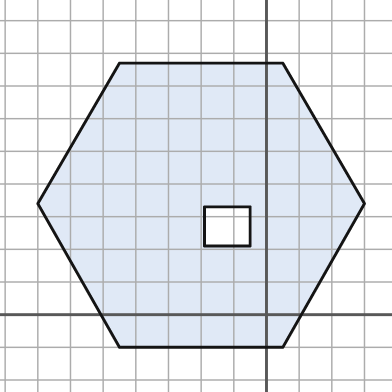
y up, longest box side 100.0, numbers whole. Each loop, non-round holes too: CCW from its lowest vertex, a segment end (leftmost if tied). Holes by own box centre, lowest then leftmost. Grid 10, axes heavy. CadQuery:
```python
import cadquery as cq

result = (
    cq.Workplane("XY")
    .moveTo(-45.0, -10.0)
    .lineTo(5.0, -10.0)
    .lineTo(30.0, 34.0)
    .lineTo(5.0, 77.0)
    .lineTo(-45.0, 77.0)
    .lineTo(-70.0, 34.0)
    .close()
    .moveTo(-19.0, 21.0)
    .lineTo(-5.0, 21.0)
    .lineTo(-5.0, 33.0)
    .lineTo(-19.0, 33.0)
    .close()
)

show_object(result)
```